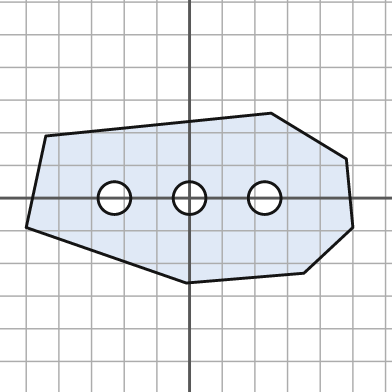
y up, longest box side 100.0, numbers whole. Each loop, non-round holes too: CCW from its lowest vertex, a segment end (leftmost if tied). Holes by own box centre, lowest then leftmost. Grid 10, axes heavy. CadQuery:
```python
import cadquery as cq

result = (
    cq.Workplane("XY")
    .moveTo(-1.0, -26.0)
    .lineTo(35.0, -23.0)
    .lineTo(50.0, -9.0)
    .lineTo(48.0, 12.0)
    .lineTo(25.0, 26.0)
    .lineTo(-44.0, 19.0)
    .lineTo(-50.0, -9.0)
    .close()
    .moveTo(-23.0, 0.0)
    .circle(5.0)
    .moveTo(0.0, 0.0)
    .circle(5.0)
    .moveTo(23.0, 0.0)
    .circle(5.0)
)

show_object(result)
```